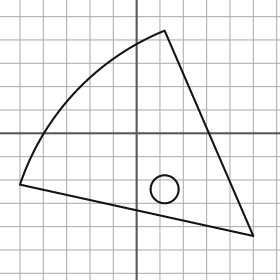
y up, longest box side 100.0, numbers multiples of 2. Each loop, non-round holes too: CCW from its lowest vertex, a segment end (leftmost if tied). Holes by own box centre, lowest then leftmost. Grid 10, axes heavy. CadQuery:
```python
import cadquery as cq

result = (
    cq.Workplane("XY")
    .moveTo(50.0, -44.0)
    .lineTo(12.0, 44.0)
    .threePointArc((-26.0, 18.0), (-50.0, -22.0))
    .close()
    .moveTo(12.0, -24.0)
    .circle(6.0)
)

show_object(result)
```